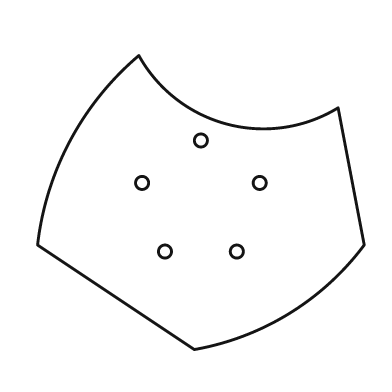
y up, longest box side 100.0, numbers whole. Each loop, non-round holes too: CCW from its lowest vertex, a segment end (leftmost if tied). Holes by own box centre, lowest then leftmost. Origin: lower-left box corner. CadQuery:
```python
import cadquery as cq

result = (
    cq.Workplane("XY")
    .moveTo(48.0, 0.0)
    .threePointArc((77.0, 11.0), (100.0, 32.0))
    .lineTo(92.0, 74.0)
    .threePointArc((58.0, 69.0), (31.0, 90.0))
    .threePointArc((10.0, 64.0), (0.0, 32.0))
    .close()
    .moveTo(39.0, 30.0)
    .circle(2.0)
    .moveTo(61.0, 30.0)
    .circle(2.0)
    .moveTo(32.0, 51.0)
    .circle(2.0)
    .moveTo(68.0, 51.0)
    .circle(2.0)
    .moveTo(50.0, 64.0)
    .circle(2.0)
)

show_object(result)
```